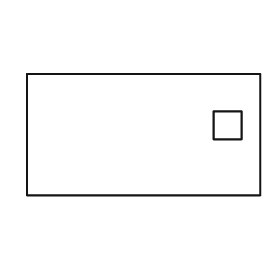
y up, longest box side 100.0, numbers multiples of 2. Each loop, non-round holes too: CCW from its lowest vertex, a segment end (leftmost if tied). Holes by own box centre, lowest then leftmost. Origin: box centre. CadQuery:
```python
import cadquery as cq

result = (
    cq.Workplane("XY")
    .moveTo(-50.0, -26.0)
    .lineTo(50.0, -26.0)
    .lineTo(50.0, 26.0)
    .lineTo(-50.0, 26.0)
    .close()
    .moveTo(30.0, -2.0)
    .lineTo(42.0, -2.0)
    .lineTo(42.0, 10.0)
    .lineTo(30.0, 10.0)
    .close()
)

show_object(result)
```